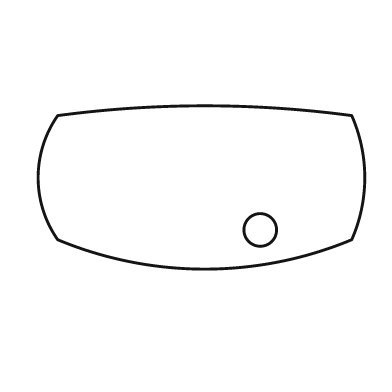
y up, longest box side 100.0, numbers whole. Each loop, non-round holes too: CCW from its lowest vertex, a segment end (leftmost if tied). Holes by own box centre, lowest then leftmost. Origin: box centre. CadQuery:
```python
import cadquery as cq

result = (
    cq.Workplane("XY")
    .moveTo(-44.0, -16.0)
    .threePointArc((1.0, -25.0), (46.0, -16.0))
    .threePointArc((50.0, 3.0), (46.0, 22.0))
    .threePointArc((1.0, 25.0), (-44.0, 22.0))
    .threePointArc((-50.0, 3.0), (-44.0, -16.0))
    .close()
    .moveTo(18.0, -13.0)
    .circle(5.0)
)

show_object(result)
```